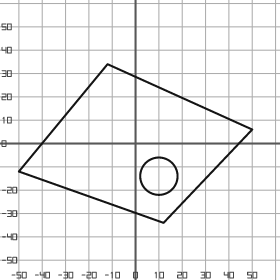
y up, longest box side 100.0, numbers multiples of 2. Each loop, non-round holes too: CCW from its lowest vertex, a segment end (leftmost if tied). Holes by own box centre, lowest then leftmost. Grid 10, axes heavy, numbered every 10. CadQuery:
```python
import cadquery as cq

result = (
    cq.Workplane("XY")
    .moveTo(12.0, -34.0)
    .lineTo(50.0, 6.0)
    .lineTo(-12.0, 34.0)
    .lineTo(-50.0, -12.0)
    .close()
    .moveTo(10.0, -14.0)
    .circle(8.0)
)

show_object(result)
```